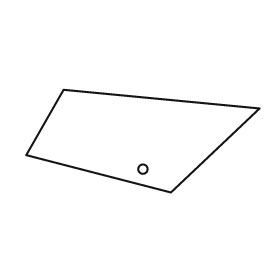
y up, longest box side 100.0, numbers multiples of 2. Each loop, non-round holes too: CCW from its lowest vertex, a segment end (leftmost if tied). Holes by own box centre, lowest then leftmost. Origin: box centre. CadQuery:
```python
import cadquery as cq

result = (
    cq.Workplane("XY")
    .moveTo(12.0, -22.0)
    .lineTo(50.0, 14.0)
    .lineTo(-34.0, 22.0)
    .lineTo(-50.0, -6.0)
    .close()
    .moveTo(0.0, -12.0)
    .circle(2.0)
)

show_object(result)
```